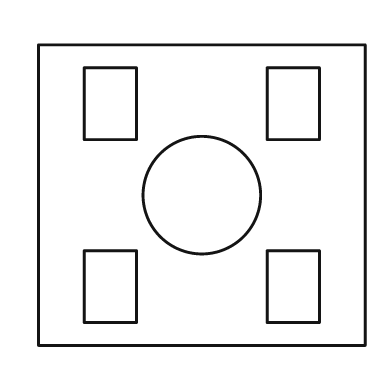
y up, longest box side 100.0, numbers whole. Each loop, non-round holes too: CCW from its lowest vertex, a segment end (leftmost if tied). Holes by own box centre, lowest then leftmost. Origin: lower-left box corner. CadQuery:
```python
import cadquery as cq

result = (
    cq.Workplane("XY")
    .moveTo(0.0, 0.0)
    .lineTo(100.0, 0.0)
    .lineTo(100.0, 92.0)
    .lineTo(0.0, 92.0)
    .close()
    .moveTo(14.0, 7.0)
    .lineTo(30.0, 7.0)
    .lineTo(30.0, 29.0)
    .lineTo(14.0, 29.0)
    .close()
    .moveTo(70.0, 7.0)
    .lineTo(86.0, 7.0)
    .lineTo(86.0, 29.0)
    .lineTo(70.0, 29.0)
    .close()
    .moveTo(50.0, 46.0)
    .circle(18.0)
    .moveTo(14.0, 63.0)
    .lineTo(30.0, 63.0)
    .lineTo(30.0, 85.0)
    .lineTo(14.0, 85.0)
    .close()
    .moveTo(70.0, 63.0)
    .lineTo(86.0, 63.0)
    .lineTo(86.0, 85.0)
    .lineTo(70.0, 85.0)
    .close()
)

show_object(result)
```